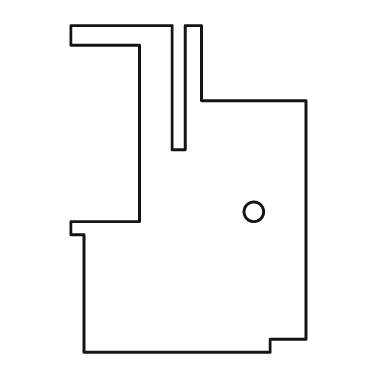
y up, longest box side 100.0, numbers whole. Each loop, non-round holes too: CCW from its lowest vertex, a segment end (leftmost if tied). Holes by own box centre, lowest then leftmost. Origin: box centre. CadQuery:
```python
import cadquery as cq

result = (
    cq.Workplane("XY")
    .moveTo(-32.0, -50.0)
    .lineTo(25.0, -50.0)
    .lineTo(25.0, -46.0)
    .lineTo(36.0, -46.0)
    .lineTo(36.0, 27.0)
    .lineTo(4.0, 27.0)
    .lineTo(4.0, 50.0)
    .lineTo(-1.0, 50.0)
    .lineTo(-1.0, 12.0)
    .lineTo(-5.0, 12.0)
    .lineTo(-5.0, 50.0)
    .lineTo(-36.0, 50.0)
    .lineTo(-36.0, 44.0)
    .lineTo(-15.0, 44.0)
    .lineTo(-15.0, -10.0)
    .lineTo(-36.0, -10.0)
    .lineTo(-36.0, -14.0)
    .lineTo(-32.0, -14.0)
    .close()
    .moveTo(20.0, -7.0)
    .circle(3.0)
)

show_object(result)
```